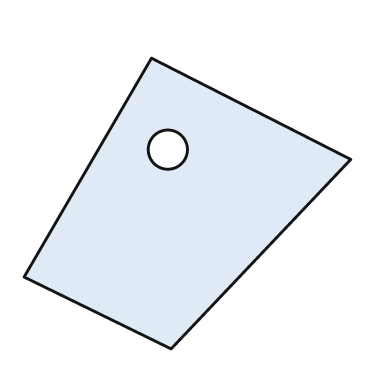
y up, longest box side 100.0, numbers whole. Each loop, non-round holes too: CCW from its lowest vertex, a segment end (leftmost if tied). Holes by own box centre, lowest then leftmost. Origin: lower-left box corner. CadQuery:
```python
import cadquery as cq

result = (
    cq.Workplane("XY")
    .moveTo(45.0, 0.0)
    .lineTo(100.0, 58.0)
    .lineTo(39.0, 89.0)
    .lineTo(0.0, 22.0)
    .close()
    .moveTo(44.0, 61.0)
    .circle(6.0)
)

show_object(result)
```